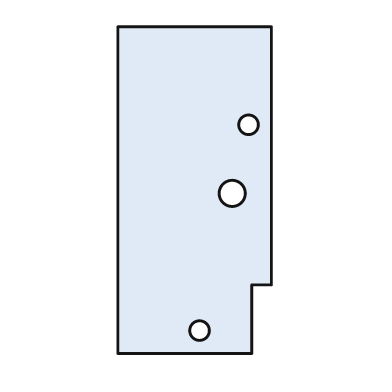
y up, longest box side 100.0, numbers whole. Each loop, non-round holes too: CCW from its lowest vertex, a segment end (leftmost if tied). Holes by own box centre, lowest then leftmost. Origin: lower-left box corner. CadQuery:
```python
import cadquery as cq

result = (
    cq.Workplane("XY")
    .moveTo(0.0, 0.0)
    .lineTo(41.0, 0.0)
    .lineTo(41.0, 21.0)
    .lineTo(47.0, 21.0)
    .lineTo(47.0, 100.0)
    .lineTo(0.0, 100.0)
    .close()
    .moveTo(25.0, 7.0)
    .circle(3.0)
    .moveTo(35.0, 49.0)
    .circle(4.0)
    .moveTo(40.0, 70.0)
    .circle(3.0)
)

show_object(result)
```